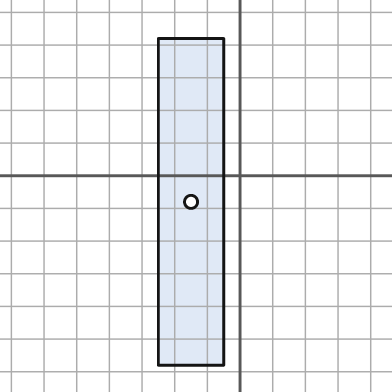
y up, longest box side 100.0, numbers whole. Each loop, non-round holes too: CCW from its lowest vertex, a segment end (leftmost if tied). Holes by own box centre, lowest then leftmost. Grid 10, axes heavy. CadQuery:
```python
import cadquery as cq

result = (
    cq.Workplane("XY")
    .moveTo(-25.0, -58.0)
    .lineTo(-5.0, -58.0)
    .lineTo(-5.0, 42.0)
    .lineTo(-25.0, 42.0)
    .close()
    .moveTo(-15.0, -8.0)
    .circle(2.0)
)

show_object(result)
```